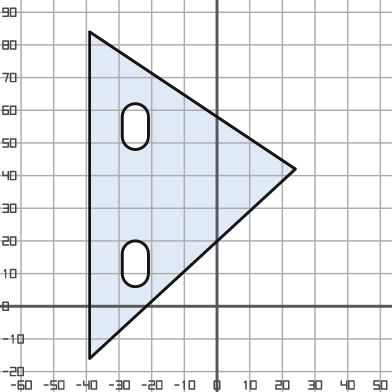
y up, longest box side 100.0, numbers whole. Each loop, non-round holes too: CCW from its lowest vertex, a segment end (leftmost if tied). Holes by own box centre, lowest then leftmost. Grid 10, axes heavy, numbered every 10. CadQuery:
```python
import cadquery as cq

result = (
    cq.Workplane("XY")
    .moveTo(-39.0, -16.0)
    .lineTo(24.0, 42.0)
    .lineTo(-39.0, 84.0)
    .close()
    .moveTo(-29.0, 10.0)
    .threePointArc((-25.0, 6.0), (-21.0, 10.0))
    .lineTo(-21.0, 16.0)
    .threePointArc((-25.0, 20.0), (-29.0, 16.0))
    .close()
    .moveTo(-29.0, 52.0)
    .threePointArc((-25.0, 48.0), (-21.0, 52.0))
    .lineTo(-21.0, 58.0)
    .threePointArc((-25.0, 62.0), (-29.0, 58.0))
    .close()
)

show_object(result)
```